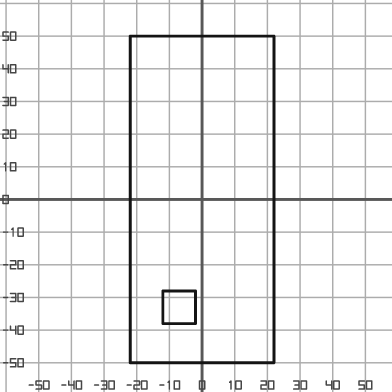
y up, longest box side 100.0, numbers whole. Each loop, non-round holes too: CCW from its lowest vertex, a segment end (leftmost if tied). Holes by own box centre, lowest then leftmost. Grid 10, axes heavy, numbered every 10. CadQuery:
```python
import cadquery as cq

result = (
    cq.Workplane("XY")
    .moveTo(-22.0, -50.0)
    .lineTo(22.0, -50.0)
    .lineTo(22.0, 50.0)
    .lineTo(-22.0, 50.0)
    .close()
    .moveTo(-12.0, -38.0)
    .lineTo(-2.0, -38.0)
    .lineTo(-2.0, -28.0)
    .lineTo(-12.0, -28.0)
    .close()
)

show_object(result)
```